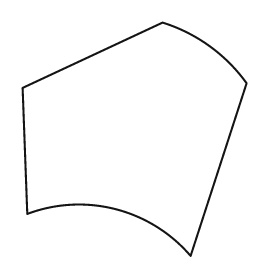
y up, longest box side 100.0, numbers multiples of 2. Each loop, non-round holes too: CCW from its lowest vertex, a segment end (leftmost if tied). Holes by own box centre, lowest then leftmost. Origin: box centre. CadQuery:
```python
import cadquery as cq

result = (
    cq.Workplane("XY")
    .moveTo(24.0, -50.0)
    .lineTo(48.0, 24.0)
    .threePointArc((32.0, 40.0), (12.0, 50.0))
    .lineTo(-48.0, 22.0)
    .lineTo(-46.0, -32.0)
    .threePointArc((-8.0, -30.0), (24.0, -50.0))
    .close()
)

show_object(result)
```